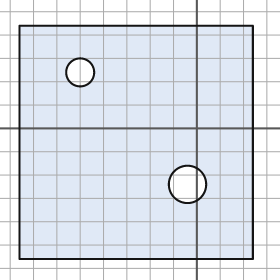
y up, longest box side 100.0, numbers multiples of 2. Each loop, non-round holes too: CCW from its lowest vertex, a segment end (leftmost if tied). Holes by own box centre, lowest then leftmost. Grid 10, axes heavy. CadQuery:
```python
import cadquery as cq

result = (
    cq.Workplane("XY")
    .moveTo(-76.0, -56.0)
    .lineTo(24.0, -56.0)
    .lineTo(24.0, 44.0)
    .lineTo(-76.0, 44.0)
    .close()
    .moveTo(-4.0, -24.0)
    .circle(8.0)
    .moveTo(-50.0, 24.0)
    .circle(6.0)
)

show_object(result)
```